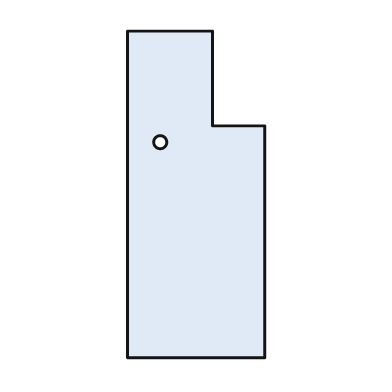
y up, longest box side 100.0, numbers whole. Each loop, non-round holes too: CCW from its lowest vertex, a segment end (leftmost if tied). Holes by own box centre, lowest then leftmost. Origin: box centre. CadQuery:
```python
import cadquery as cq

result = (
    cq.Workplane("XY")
    .moveTo(-21.0, -50.0)
    .lineTo(21.0, -50.0)
    .lineTo(21.0, 21.0)
    .lineTo(5.0, 21.0)
    .lineTo(5.0, 50.0)
    .lineTo(-21.0, 50.0)
    .close()
    .moveTo(-11.0, 16.0)
    .circle(2.0)
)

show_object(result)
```